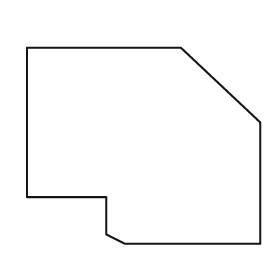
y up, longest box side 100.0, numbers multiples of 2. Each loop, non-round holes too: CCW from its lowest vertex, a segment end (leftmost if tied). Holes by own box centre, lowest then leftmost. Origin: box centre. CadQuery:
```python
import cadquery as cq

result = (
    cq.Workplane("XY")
    .moveTo(-8.0, -42.0)
    .lineTo(50.0, -42.0)
    .lineTo(50.0, 10.0)
    .lineTo(16.0, 42.0)
    .lineTo(-50.0, 42.0)
    .lineTo(-50.0, -22.0)
    .lineTo(-16.0, -22.0)
    .lineTo(-16.0, -38.0)
    .close()
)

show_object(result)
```